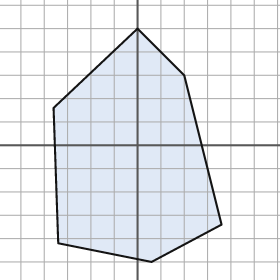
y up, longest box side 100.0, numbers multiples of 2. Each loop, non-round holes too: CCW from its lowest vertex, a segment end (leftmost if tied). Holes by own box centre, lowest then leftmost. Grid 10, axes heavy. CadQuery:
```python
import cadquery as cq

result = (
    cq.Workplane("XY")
    .moveTo(6.0, -50.0)
    .lineTo(36.0, -34.0)
    .lineTo(20.0, 30.0)
    .lineTo(0.0, 50.0)
    .lineTo(-36.0, 16.0)
    .lineTo(-34.0, -42.0)
    .close()
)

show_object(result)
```